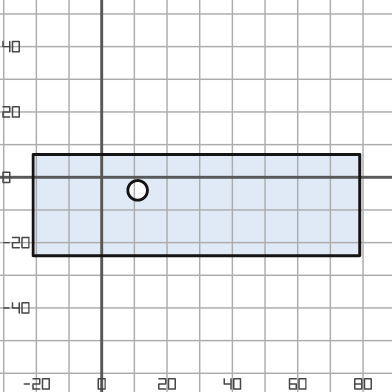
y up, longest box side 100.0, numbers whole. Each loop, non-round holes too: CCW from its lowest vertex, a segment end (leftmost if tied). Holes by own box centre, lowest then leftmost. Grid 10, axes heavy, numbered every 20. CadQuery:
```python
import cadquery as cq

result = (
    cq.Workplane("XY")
    .moveTo(-21.0, -24.0)
    .lineTo(79.0, -24.0)
    .lineTo(79.0, 7.0)
    .lineTo(-21.0, 7.0)
    .close()
    .moveTo(11.0, -4.0)
    .circle(3.0)
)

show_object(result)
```